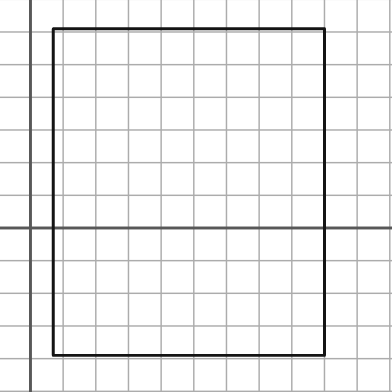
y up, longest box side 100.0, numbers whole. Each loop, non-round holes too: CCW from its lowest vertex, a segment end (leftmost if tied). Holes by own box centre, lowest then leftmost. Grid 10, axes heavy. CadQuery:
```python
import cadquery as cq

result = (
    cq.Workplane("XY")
    .moveTo(7.0, -39.0)
    .lineTo(90.0, -39.0)
    .lineTo(90.0, 61.0)
    .lineTo(7.0, 61.0)
    .close()
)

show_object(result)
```